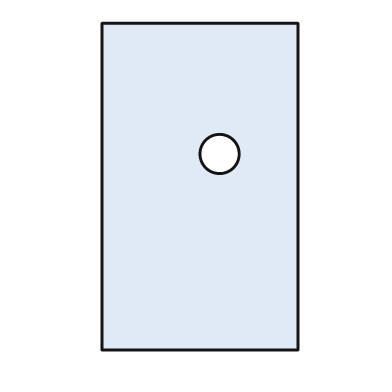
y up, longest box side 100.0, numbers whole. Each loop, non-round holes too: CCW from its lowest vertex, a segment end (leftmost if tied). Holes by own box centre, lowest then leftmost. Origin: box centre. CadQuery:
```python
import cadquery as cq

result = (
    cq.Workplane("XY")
    .moveTo(-30.0, -50.0)
    .lineTo(30.0, -50.0)
    .lineTo(30.0, 50.0)
    .lineTo(-30.0, 50.0)
    .close()
    .moveTo(6.0, 10.0)
    .circle(6.0)
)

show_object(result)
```